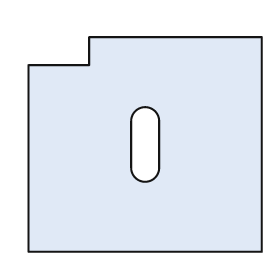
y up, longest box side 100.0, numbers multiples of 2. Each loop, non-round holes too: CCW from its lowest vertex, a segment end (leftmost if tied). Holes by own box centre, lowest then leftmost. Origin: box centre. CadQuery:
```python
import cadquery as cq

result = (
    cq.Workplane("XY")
    .moveTo(-50.0, -46.0)
    .lineTo(50.0, -46.0)
    .lineTo(50.0, 46.0)
    .lineTo(-24.0, 46.0)
    .lineTo(-24.0, 34.0)
    .lineTo(-50.0, 34.0)
    .close()
    .moveTo(-6.0, -10.0)
    .threePointArc((0.0, -16.0), (6.0, -10.0))
    .lineTo(6.0, 10.0)
    .threePointArc((0.0, 16.0), (-6.0, 10.0))
    .close()
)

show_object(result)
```